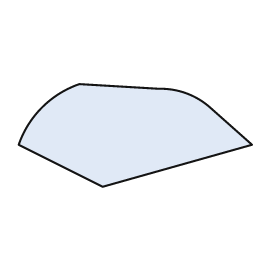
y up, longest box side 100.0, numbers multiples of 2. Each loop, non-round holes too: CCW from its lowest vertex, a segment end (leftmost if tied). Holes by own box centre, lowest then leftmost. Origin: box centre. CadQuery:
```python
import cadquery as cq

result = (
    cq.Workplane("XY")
    .moveTo(-14.0, -22.0)
    .lineTo(50.0, -4.0)
    .lineTo(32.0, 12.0)
    .threePointArc((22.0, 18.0), (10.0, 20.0))
    .lineTo(-24.0, 22.0)
    .threePointArc((-40.0, 12.0), (-50.0, -4.0))
    .close()
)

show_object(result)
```